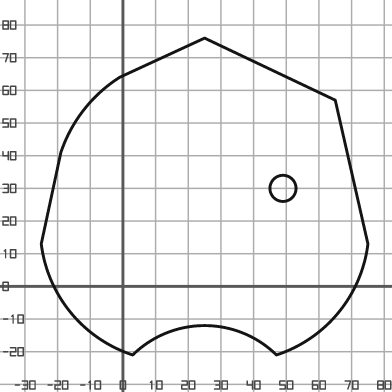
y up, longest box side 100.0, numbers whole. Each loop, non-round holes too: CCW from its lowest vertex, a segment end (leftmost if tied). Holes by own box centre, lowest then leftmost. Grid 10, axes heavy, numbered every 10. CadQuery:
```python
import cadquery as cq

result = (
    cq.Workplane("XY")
    .moveTo(3.0, -21.0)
    .threePointArc((25.0, -12.0), (47.0, -21.0))
    .threePointArc((66.0, -8.0), (75.0, 13.0))
    .lineTo(65.0, 57.0)
    .lineTo(25.0, 76.0)
    .lineTo(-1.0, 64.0)
    .threePointArc((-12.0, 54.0), (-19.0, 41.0))
    .lineTo(-25.0, 13.0)
    .threePointArc((-16.0, -8.0), (3.0, -21.0))
    .close()
    .moveTo(49.0, 30.0)
    .circle(4.0)
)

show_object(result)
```